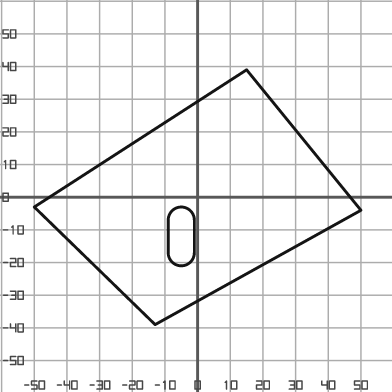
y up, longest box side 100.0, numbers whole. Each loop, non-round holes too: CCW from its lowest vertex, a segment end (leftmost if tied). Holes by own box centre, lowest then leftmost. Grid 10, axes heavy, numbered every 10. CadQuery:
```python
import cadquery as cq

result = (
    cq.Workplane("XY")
    .moveTo(-13.0, -39.0)
    .lineTo(50.0, -4.0)
    .lineTo(15.0, 39.0)
    .lineTo(-50.0, -3.0)
    .close()
    .moveTo(-9.0, -17.0)
    .threePointArc((-5.0, -21.0), (-1.0, -17.0))
    .lineTo(-1.0, -7.0)
    .threePointArc((-5.0, -3.0), (-9.0, -7.0))
    .close()
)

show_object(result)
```